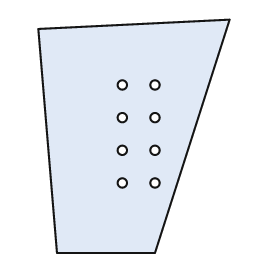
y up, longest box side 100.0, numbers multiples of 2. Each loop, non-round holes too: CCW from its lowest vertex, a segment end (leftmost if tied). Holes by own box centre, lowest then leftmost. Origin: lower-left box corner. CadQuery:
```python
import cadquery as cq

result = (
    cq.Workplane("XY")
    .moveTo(8.0, 0.0)
    .lineTo(50.0, 0.0)
    .lineTo(82.0, 100.0)
    .lineTo(0.0, 96.0)
    .close()
    .moveTo(36.0, 30.0)
    .circle(2.0)
    .moveTo(50.0, 30.0)
    .circle(2.0)
    .moveTo(36.0, 44.0)
    .circle(2.0)
    .moveTo(50.0, 44.0)
    .circle(2.0)
    .moveTo(36.0, 58.0)
    .circle(2.0)
    .moveTo(50.0, 58.0)
    .circle(2.0)
    .moveTo(36.0, 72.0)
    .circle(2.0)
    .moveTo(50.0, 72.0)
    .circle(2.0)
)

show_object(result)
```